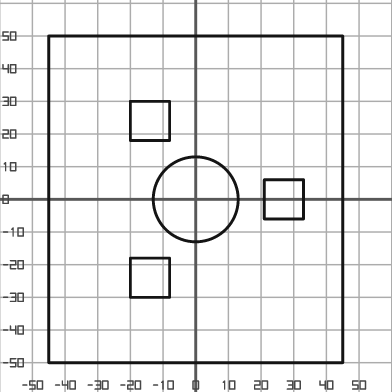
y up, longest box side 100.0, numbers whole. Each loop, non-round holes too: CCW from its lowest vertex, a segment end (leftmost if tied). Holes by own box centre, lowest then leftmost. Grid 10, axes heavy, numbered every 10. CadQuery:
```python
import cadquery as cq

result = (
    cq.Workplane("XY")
    .moveTo(-45.0, -50.0)
    .lineTo(45.0, -50.0)
    .lineTo(45.0, 50.0)
    .lineTo(-45.0, 50.0)
    .close()
    .moveTo(-20.0, -30.0)
    .lineTo(-8.0, -30.0)
    .lineTo(-8.0, -18.0)
    .lineTo(-20.0, -18.0)
    .close()
    .moveTo(0.0, 0.0)
    .circle(13.0)
    .moveTo(21.0, -6.0)
    .lineTo(33.0, -6.0)
    .lineTo(33.0, 6.0)
    .lineTo(21.0, 6.0)
    .close()
    .moveTo(-20.0, 18.0)
    .lineTo(-8.0, 18.0)
    .lineTo(-8.0, 30.0)
    .lineTo(-20.0, 30.0)
    .close()
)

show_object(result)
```